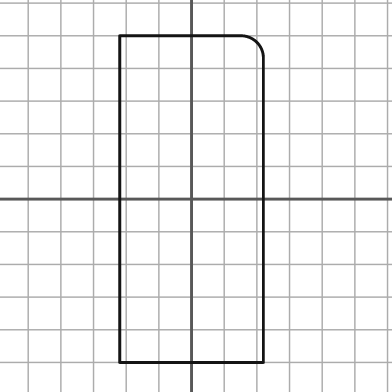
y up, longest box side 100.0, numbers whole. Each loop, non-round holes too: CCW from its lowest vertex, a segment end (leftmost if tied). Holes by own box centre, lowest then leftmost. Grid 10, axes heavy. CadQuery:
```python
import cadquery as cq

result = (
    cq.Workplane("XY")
    .moveTo(-22.0, -50.0)
    .lineTo(22.0, -50.0)
    .lineTo(22.0, 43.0)
    .threePointArc((20.0, 48.0), (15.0, 50.0))
    .lineTo(-22.0, 50.0)
    .close()
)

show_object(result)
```